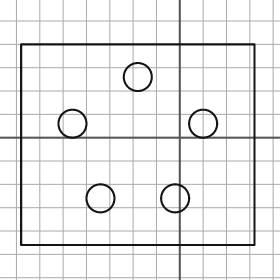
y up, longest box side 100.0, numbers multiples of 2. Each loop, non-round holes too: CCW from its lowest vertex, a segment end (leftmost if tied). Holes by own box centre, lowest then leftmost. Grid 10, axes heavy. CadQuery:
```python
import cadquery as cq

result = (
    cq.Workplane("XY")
    .moveTo(-68.0, -46.0)
    .lineTo(32.0, -46.0)
    .lineTo(32.0, 40.0)
    .lineTo(-68.0, 40.0)
    .close()
    .moveTo(-34.0, -26.0)
    .circle(6.0)
    .moveTo(-2.0, -26.0)
    .circle(6.0)
    .moveTo(-46.0, 6.0)
    .circle(6.0)
    .moveTo(10.0, 6.0)
    .circle(6.0)
    .moveTo(-18.0, 26.0)
    .circle(6.0)
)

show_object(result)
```